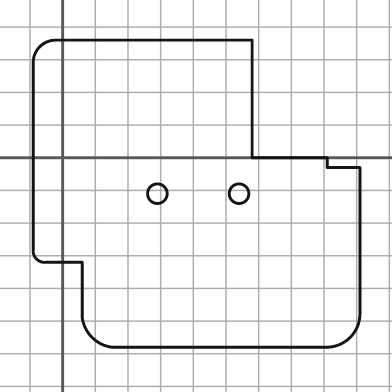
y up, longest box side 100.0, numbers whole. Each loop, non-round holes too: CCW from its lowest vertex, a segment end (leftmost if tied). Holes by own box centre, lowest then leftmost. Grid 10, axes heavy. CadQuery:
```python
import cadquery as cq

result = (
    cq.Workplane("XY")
    .moveTo(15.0, -58.0)
    .lineTo(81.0, -58.0)
    .threePointArc((88.0, -55.0), (91.0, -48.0))
    .lineTo(91.0, -3.0)
    .lineTo(81.0, -3.0)
    .lineTo(81.0, 0.0)
    .lineTo(58.0, 0.0)
    .lineTo(58.0, 36.0)
    .lineTo(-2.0, 36.0)
    .threePointArc((-7.0, 34.0), (-9.0, 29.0))
    .lineTo(-9.0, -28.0)
    .threePointArc((-8.0, -31.0), (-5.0, -32.0))
    .lineTo(6.0, -32.0)
    .lineTo(6.0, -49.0)
    .threePointArc((9.0, -55.0), (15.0, -58.0))
    .close()
    .moveTo(29.0, -11.0)
    .circle(3.0)
    .moveTo(54.0, -11.0)
    .circle(3.0)
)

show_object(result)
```